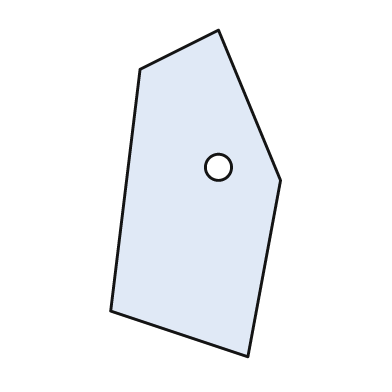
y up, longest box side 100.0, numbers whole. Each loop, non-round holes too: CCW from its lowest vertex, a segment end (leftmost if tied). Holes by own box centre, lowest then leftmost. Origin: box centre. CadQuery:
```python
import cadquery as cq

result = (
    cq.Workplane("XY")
    .moveTo(16.0, -50.0)
    .lineTo(26.0, 4.0)
    .lineTo(7.0, 50.0)
    .lineTo(-17.0, 38.0)
    .lineTo(-26.0, -36.0)
    .close()
    .moveTo(7.0, 8.0)
    .circle(4.0)
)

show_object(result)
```